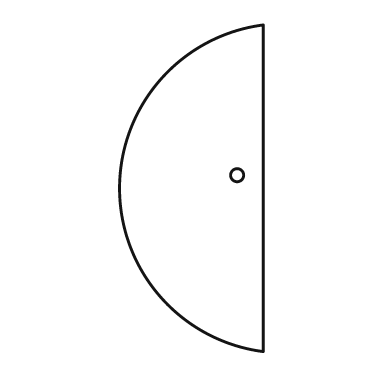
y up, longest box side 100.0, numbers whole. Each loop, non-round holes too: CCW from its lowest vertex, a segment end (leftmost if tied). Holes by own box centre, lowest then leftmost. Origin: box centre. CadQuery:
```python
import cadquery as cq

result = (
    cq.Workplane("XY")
    .moveTo(22.0, -50.0)
    .lineTo(22.0, 50.0)
    .threePointArc((-22.0, 0.0), (22.0, -50.0))
    .close()
    .moveTo(14.0, 4.0)
    .circle(2.0)
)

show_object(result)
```